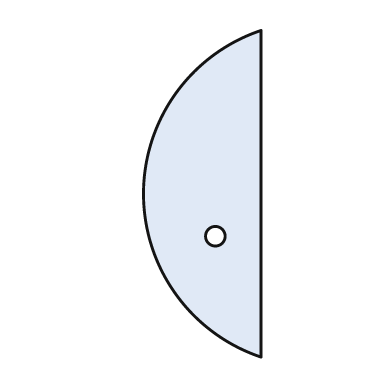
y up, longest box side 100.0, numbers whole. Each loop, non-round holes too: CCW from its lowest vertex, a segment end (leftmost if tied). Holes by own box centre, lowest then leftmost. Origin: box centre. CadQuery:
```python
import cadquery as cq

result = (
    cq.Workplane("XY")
    .moveTo(18.0, -50.0)
    .lineTo(18.0, 50.0)
    .threePointArc((-18.0, 0.0), (18.0, -50.0))
    .close()
    .moveTo(4.0, -13.0)
    .circle(3.0)
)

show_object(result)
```